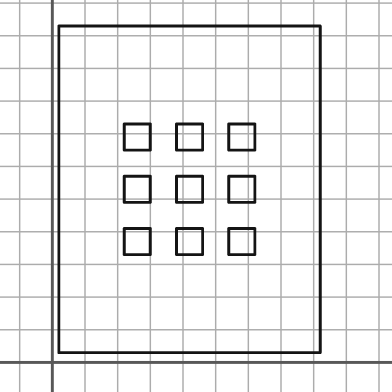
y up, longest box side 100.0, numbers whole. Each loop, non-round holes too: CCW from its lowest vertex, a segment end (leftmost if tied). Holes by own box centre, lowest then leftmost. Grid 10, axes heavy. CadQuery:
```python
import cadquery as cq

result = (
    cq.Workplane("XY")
    .moveTo(2.0, 3.0)
    .lineTo(82.0, 3.0)
    .lineTo(82.0, 103.0)
    .lineTo(2.0, 103.0)
    .close()
    .moveTo(22.0, 33.0)
    .lineTo(30.0, 33.0)
    .lineTo(30.0, 41.0)
    .lineTo(22.0, 41.0)
    .close()
    .moveTo(38.0, 33.0)
    .lineTo(46.0, 33.0)
    .lineTo(46.0, 41.0)
    .lineTo(38.0, 41.0)
    .close()
    .moveTo(54.0, 33.0)
    .lineTo(62.0, 33.0)
    .lineTo(62.0, 41.0)
    .lineTo(54.0, 41.0)
    .close()
    .moveTo(22.0, 49.0)
    .lineTo(30.0, 49.0)
    .lineTo(30.0, 57.0)
    .lineTo(22.0, 57.0)
    .close()
    .moveTo(38.0, 49.0)
    .lineTo(46.0, 49.0)
    .lineTo(46.0, 57.0)
    .lineTo(38.0, 57.0)
    .close()
    .moveTo(54.0, 49.0)
    .lineTo(62.0, 49.0)
    .lineTo(62.0, 57.0)
    .lineTo(54.0, 57.0)
    .close()
    .moveTo(22.0, 65.0)
    .lineTo(30.0, 65.0)
    .lineTo(30.0, 73.0)
    .lineTo(22.0, 73.0)
    .close()
    .moveTo(38.0, 65.0)
    .lineTo(46.0, 65.0)
    .lineTo(46.0, 73.0)
    .lineTo(38.0, 73.0)
    .close()
    .moveTo(54.0, 65.0)
    .lineTo(62.0, 65.0)
    .lineTo(62.0, 73.0)
    .lineTo(54.0, 73.0)
    .close()
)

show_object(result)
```